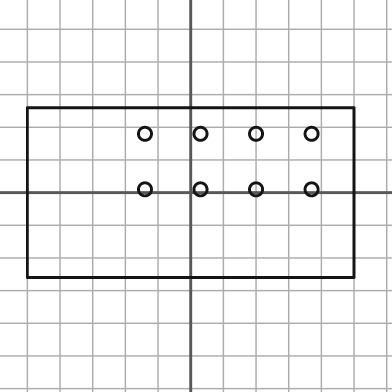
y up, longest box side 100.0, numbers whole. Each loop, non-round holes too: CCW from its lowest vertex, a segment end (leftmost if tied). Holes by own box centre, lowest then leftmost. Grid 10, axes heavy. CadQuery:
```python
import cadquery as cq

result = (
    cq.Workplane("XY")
    .moveTo(-50.0, -26.0)
    .lineTo(50.0, -26.0)
    .lineTo(50.0, 26.0)
    .lineTo(-50.0, 26.0)
    .close()
    .moveTo(-14.0, 1.0)
    .circle(2.0)
    .moveTo(3.0, 1.0)
    .circle(2.0)
    .moveTo(20.0, 1.0)
    .circle(2.0)
    .moveTo(37.0, 1.0)
    .circle(2.0)
    .moveTo(-14.0, 18.0)
    .circle(2.0)
    .moveTo(3.0, 18.0)
    .circle(2.0)
    .moveTo(20.0, 18.0)
    .circle(2.0)
    .moveTo(37.0, 18.0)
    .circle(2.0)
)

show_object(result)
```